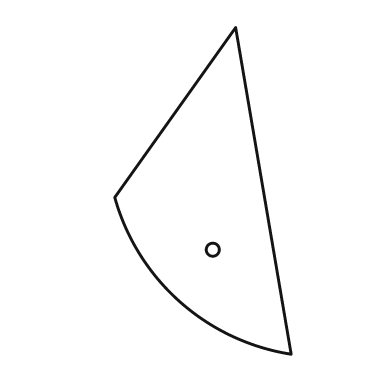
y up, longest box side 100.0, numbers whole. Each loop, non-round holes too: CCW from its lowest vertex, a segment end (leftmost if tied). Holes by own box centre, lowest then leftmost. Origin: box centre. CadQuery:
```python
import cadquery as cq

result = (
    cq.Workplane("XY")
    .moveTo(27.0, -50.0)
    .lineTo(10.0, 50.0)
    .lineTo(-27.0, -2.0)
    .threePointArc((-7.0, -34.0), (27.0, -50.0))
    .close()
    .moveTo(3.0, -18.0)
    .circle(2.0)
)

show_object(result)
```